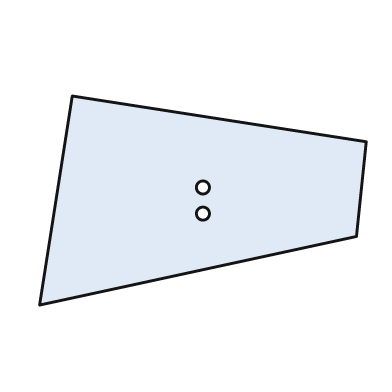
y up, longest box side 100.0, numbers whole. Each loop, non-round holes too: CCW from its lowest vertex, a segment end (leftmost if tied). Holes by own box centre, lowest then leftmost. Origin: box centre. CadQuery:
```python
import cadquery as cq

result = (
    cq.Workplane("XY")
    .moveTo(-50.0, -32.0)
    .lineTo(47.0, -11.0)
    .lineTo(50.0, 18.0)
    .lineTo(-40.0, 32.0)
    .close()
    .moveTo(0.0, -4.0)
    .circle(2.0)
    .moveTo(0.0, 4.0)
    .circle(2.0)
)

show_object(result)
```